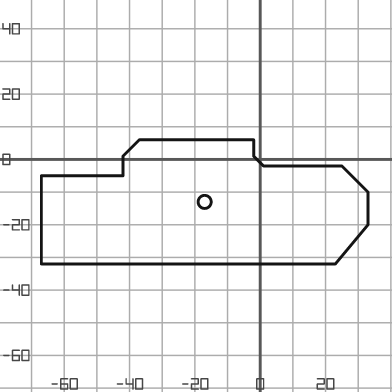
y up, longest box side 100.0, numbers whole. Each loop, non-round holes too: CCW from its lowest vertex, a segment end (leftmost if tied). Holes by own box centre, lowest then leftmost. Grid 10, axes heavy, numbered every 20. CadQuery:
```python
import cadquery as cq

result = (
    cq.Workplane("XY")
    .moveTo(-67.0, -32.0)
    .lineTo(23.0, -32.0)
    .lineTo(33.0, -20.0)
    .lineTo(33.0, -10.0)
    .lineTo(25.0, -2.0)
    .lineTo(1.0, -2.0)
    .lineTo(-2.0, 1.0)
    .lineTo(-2.0, 6.0)
    .lineTo(-37.0, 6.0)
    .lineTo(-42.0, 1.0)
    .lineTo(-42.0, -5.0)
    .lineTo(-67.0, -5.0)
    .close()
    .moveTo(-17.0, -13.0)
    .circle(2.0)
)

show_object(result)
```